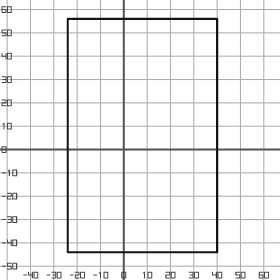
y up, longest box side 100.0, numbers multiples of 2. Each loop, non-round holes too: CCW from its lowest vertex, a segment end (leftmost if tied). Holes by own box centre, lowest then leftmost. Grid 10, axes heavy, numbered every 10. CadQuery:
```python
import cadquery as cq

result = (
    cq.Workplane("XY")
    .moveTo(-24.0, -44.0)
    .lineTo(40.0, -44.0)
    .lineTo(40.0, 56.0)
    .lineTo(-24.0, 56.0)
    .close()
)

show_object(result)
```